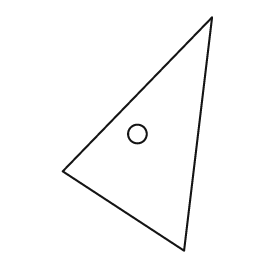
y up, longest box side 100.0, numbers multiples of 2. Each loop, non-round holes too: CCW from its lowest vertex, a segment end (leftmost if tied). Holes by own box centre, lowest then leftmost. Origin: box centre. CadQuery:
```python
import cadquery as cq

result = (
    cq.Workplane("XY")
    .moveTo(20.0, -50.0)
    .lineTo(32.0, 50.0)
    .lineTo(-32.0, -16.0)
    .close()
    .moveTo(0.0, 0.0)
    .circle(4.0)
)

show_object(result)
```